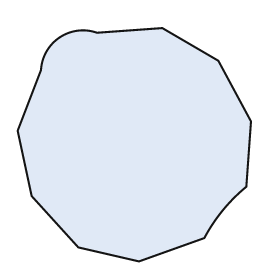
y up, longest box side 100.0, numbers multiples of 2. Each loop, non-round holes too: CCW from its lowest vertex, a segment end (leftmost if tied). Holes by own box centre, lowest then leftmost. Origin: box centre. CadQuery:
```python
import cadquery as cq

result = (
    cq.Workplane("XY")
    .moveTo(2.0, -50.0)
    .lineTo(30.0, -40.0)
    .threePointArc((38.0, -28.0), (48.0, -18.0))
    .lineTo(50.0, 10.0)
    .lineTo(36.0, 36.0)
    .lineTo(12.0, 50.0)
    .lineTo(-16.0, 48.0)
    .threePointArc((-32.0, 46.0), (-40.0, 32.0))
    .lineTo(-50.0, 6.0)
    .lineTo(-44.0, -22.0)
    .lineTo(-24.0, -44.0)
    .close()
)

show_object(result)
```